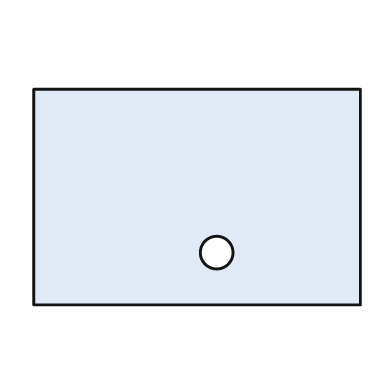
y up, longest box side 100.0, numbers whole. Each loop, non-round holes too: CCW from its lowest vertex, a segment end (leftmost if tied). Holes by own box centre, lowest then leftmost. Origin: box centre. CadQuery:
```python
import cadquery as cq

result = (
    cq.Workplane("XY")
    .moveTo(-50.0, -33.0)
    .lineTo(50.0, -33.0)
    .lineTo(50.0, 33.0)
    .lineTo(-50.0, 33.0)
    .close()
    .moveTo(6.0, -17.0)
    .circle(5.0)
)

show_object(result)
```